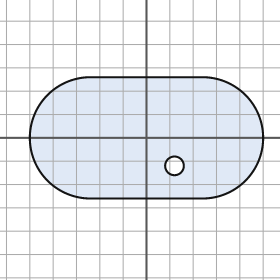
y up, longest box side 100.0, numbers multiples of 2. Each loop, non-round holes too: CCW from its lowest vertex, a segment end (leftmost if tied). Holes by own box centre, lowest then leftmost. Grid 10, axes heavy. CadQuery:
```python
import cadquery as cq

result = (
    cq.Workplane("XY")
    .moveTo(-24.0, -26.0)
    .lineTo(24.0, -26.0)
    .threePointArc((50.0, 0.0), (24.0, 26.0))
    .lineTo(-24.0, 26.0)
    .threePointArc((-50.0, 0.0), (-24.0, -26.0))
    .close()
    .moveTo(12.0, -12.0)
    .circle(4.0)
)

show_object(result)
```